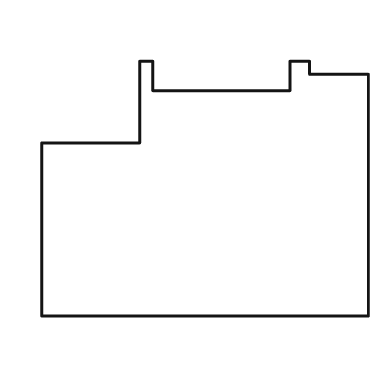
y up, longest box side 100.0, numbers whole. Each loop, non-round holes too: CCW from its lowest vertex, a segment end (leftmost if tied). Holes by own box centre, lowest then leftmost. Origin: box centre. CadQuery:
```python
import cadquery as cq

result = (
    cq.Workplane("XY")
    .moveTo(-50.0, -39.0)
    .lineTo(50.0, -39.0)
    .lineTo(50.0, 35.0)
    .lineTo(32.0, 35.0)
    .lineTo(32.0, 39.0)
    .lineTo(26.0, 39.0)
    .lineTo(26.0, 30.0)
    .lineTo(-16.0, 30.0)
    .lineTo(-16.0, 39.0)
    .lineTo(-20.0, 39.0)
    .lineTo(-20.0, 14.0)
    .lineTo(-50.0, 14.0)
    .close()
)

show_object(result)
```